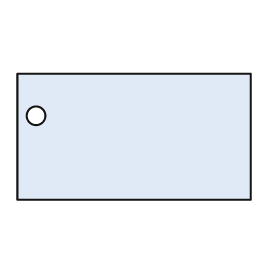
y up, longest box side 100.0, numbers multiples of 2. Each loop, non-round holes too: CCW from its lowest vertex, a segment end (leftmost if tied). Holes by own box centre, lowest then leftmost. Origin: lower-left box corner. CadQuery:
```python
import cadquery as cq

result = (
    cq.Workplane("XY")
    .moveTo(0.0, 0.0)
    .lineTo(100.0, 0.0)
    .lineTo(100.0, 54.0)
    .lineTo(0.0, 54.0)
    .close()
    .moveTo(8.0, 36.0)
    .circle(4.0)
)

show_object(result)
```